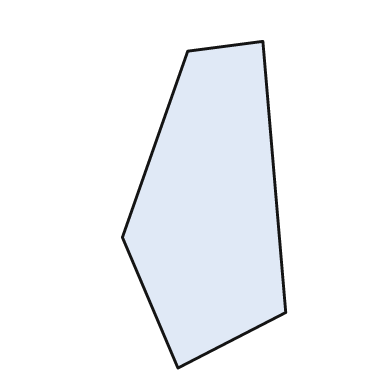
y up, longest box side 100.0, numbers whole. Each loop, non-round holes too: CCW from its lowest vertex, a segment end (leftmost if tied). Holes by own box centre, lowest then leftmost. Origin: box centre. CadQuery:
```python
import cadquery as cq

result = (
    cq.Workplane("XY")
    .moveTo(-8.0, -50.0)
    .lineTo(25.0, -33.0)
    .lineTo(18.0, 50.0)
    .lineTo(-5.0, 47.0)
    .lineTo(-25.0, -10.0)
    .close()
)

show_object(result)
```